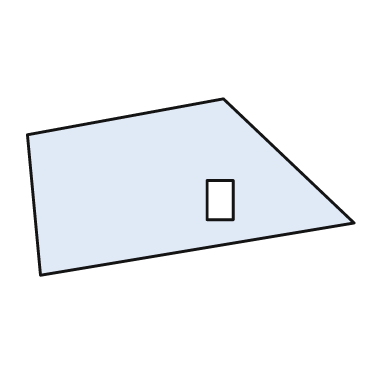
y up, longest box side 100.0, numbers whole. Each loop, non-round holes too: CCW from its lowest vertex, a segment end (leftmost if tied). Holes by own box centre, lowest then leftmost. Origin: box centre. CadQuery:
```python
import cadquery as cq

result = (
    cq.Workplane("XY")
    .moveTo(-46.0, -27.0)
    .lineTo(50.0, -11.0)
    .lineTo(10.0, 27.0)
    .lineTo(-50.0, 16.0)
    .close()
    .moveTo(5.0, -10.0)
    .lineTo(13.0, -10.0)
    .lineTo(13.0, 2.0)
    .lineTo(5.0, 2.0)
    .close()
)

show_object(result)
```